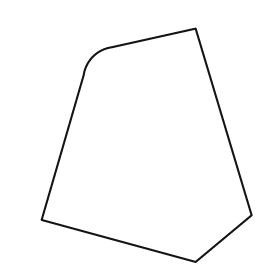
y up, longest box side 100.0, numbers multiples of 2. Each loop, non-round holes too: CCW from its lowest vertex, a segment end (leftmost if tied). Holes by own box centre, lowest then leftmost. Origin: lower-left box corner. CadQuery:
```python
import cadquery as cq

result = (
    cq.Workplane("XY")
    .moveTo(66.0, 0.0)
    .lineTo(90.0, 20.0)
    .lineTo(66.0, 100.0)
    .lineTo(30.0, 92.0)
    .threePointArc((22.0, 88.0), (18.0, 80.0))
    .lineTo(0.0, 18.0)
    .close()
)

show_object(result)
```